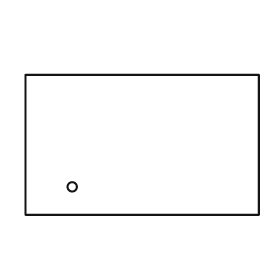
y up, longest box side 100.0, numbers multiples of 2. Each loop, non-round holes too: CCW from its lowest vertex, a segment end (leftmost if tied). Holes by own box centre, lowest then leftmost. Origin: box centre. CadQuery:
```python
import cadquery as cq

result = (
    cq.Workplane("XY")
    .moveTo(-50.0, -30.0)
    .lineTo(50.0, -30.0)
    .lineTo(50.0, 30.0)
    .lineTo(-50.0, 30.0)
    .close()
    .moveTo(-30.0, -18.0)
    .circle(2.0)
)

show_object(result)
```